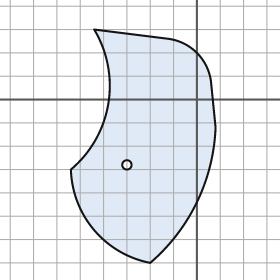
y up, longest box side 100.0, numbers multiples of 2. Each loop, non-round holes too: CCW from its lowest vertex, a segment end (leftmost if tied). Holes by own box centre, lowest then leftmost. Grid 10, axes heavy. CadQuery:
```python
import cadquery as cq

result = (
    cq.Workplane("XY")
    .moveTo(-20.0, -70.0)
    .threePointArc((0.0, -44.0), (8.0, -12.0))
    .lineTo(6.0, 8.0)
    .threePointArc((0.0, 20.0), (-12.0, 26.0))
    .lineTo(-44.0, 30.0)
    .threePointArc((-38.0, -2.0), (-54.0, -30.0))
    .threePointArc((-44.0, -56.0), (-20.0, -70.0))
    .close()
    .moveTo(-30.0, -28.0)
    .circle(2.0)
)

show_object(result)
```